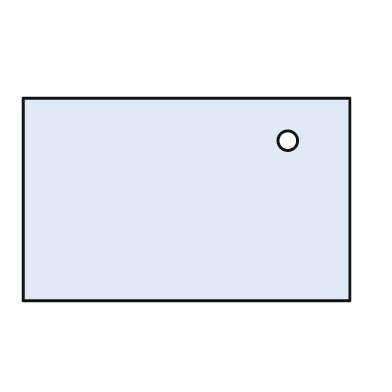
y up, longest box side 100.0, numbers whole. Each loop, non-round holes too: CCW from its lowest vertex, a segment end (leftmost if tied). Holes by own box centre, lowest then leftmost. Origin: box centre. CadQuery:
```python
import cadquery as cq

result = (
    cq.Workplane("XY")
    .moveTo(-50.0, -31.0)
    .lineTo(50.0, -31.0)
    .lineTo(50.0, 31.0)
    .lineTo(-50.0, 31.0)
    .close()
    .moveTo(31.0, 18.0)
    .circle(3.0)
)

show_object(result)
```